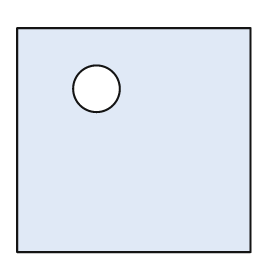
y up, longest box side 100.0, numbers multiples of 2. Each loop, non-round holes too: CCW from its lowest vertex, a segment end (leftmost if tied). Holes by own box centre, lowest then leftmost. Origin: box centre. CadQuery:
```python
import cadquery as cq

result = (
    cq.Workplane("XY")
    .moveTo(-50.0, -48.0)
    .lineTo(50.0, -48.0)
    .lineTo(50.0, 48.0)
    .lineTo(-50.0, 48.0)
    .close()
    .moveTo(-16.0, 22.0)
    .circle(10.0)
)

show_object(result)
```